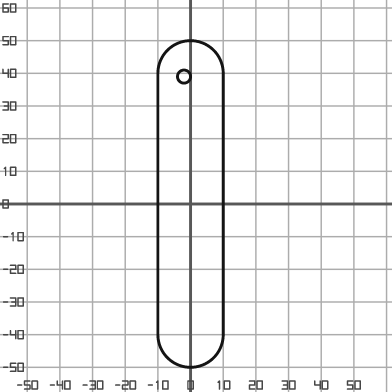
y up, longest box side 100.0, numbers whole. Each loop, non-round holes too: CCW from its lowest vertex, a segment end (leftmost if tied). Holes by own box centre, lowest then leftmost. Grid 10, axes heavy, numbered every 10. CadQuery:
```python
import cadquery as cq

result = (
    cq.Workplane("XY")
    .moveTo(-10.0, -40.0)
    .threePointArc((0.0, -50.0), (10.0, -40.0))
    .lineTo(10.0, 40.0)
    .threePointArc((0.0, 50.0), (-10.0, 40.0))
    .close()
    .moveTo(-2.0, 39.0)
    .circle(2.0)
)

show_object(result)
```